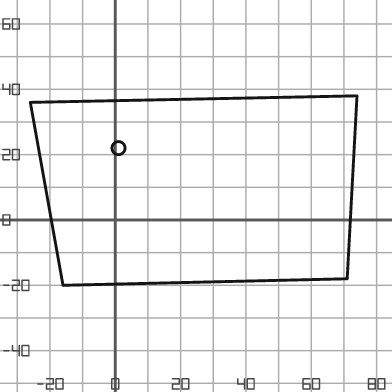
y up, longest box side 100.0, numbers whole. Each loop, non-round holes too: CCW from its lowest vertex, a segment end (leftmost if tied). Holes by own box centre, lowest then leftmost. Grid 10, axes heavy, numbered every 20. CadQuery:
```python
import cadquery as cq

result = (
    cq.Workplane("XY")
    .moveTo(-16.0, -20.0)
    .lineTo(71.0, -18.0)
    .lineTo(74.0, 38.0)
    .lineTo(-26.0, 36.0)
    .close()
    .moveTo(1.0, 22.0)
    .circle(2.0)
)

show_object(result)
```